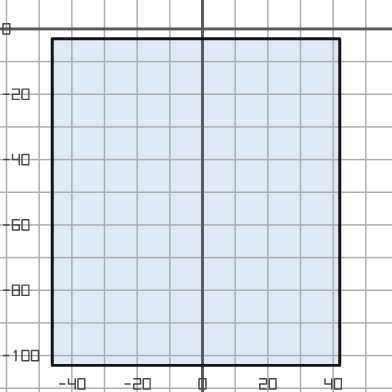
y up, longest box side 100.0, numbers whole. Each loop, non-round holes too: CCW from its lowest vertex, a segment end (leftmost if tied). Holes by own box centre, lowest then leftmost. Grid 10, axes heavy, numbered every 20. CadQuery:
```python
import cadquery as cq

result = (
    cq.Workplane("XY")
    .moveTo(-46.0, -103.0)
    .lineTo(42.0, -103.0)
    .lineTo(42.0, -3.0)
    .lineTo(-46.0, -3.0)
    .close()
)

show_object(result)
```